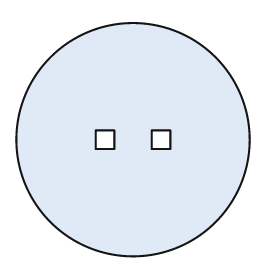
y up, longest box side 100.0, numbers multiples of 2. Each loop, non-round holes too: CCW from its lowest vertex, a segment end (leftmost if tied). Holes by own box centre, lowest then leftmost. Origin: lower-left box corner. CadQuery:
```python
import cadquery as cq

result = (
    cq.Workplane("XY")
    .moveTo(50.0, 50.0)
    .circle(50.0)
    .moveTo(34.0, 46.0)
    .lineTo(42.0, 46.0)
    .lineTo(42.0, 54.0)
    .lineTo(34.0, 54.0)
    .close()
    .moveTo(58.0, 46.0)
    .lineTo(66.0, 46.0)
    .lineTo(66.0, 54.0)
    .lineTo(58.0, 54.0)
    .close()
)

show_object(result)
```